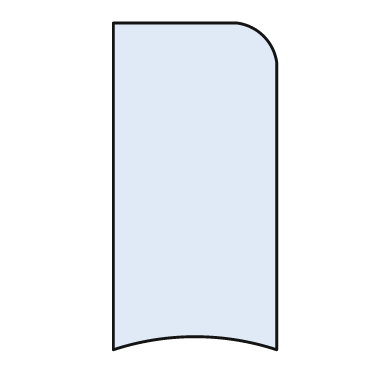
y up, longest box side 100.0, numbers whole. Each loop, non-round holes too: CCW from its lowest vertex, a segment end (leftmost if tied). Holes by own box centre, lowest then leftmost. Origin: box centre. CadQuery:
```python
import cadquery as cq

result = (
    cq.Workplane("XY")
    .moveTo(-25.0, -50.0)
    .threePointArc((0.0, -46.0), (25.0, -50.0))
    .lineTo(25.0, 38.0)
    .threePointArc((21.0, 46.0), (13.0, 50.0))
    .lineTo(-25.0, 50.0)
    .close()
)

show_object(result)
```